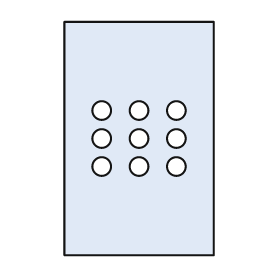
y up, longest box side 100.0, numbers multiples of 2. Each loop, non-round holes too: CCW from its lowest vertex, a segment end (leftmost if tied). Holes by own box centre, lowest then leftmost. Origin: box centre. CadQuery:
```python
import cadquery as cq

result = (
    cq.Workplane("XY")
    .moveTo(-32.0, -50.0)
    .lineTo(32.0, -50.0)
    .lineTo(32.0, 50.0)
    .lineTo(-32.0, 50.0)
    .close()
    .moveTo(-16.0, -12.0)
    .circle(4.0)
    .moveTo(0.0, -12.0)
    .circle(4.0)
    .moveTo(16.0, -12.0)
    .circle(4.0)
    .moveTo(-16.0, 0.0)
    .circle(4.0)
    .moveTo(0.0, 0.0)
    .circle(4.0)
    .moveTo(16.0, 0.0)
    .circle(4.0)
    .moveTo(-16.0, 12.0)
    .circle(4.0)
    .moveTo(0.0, 12.0)
    .circle(4.0)
    .moveTo(16.0, 12.0)
    .circle(4.0)
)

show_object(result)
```